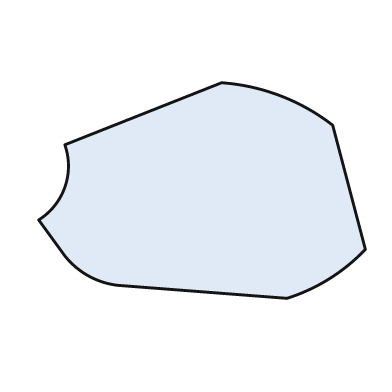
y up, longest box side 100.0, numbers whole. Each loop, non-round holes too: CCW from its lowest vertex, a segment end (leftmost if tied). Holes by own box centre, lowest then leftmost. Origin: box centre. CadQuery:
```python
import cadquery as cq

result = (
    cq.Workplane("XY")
    .moveTo(26.0, -33.0)
    .threePointArc((39.0, -27.0), (50.0, -18.0))
    .lineTo(40.0, 20.0)
    .threePointArc((24.0, 29.0), (6.0, 33.0))
    .lineTo(-42.0, 14.0)
    .threePointArc((-42.0, 1.0), (-50.0, -9.0))
    .lineTo(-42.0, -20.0)
    .threePointArc((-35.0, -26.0), (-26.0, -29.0))
    .close()
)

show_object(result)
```